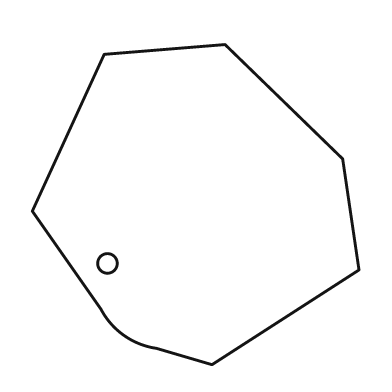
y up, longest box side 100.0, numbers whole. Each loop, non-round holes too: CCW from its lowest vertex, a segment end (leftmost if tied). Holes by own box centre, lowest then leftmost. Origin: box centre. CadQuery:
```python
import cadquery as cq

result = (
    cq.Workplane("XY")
    .moveTo(5.0, -49.0)
    .lineTo(50.0, -20.0)
    .lineTo(45.0, 14.0)
    .lineTo(9.0, 49.0)
    .lineTo(-28.0, 46.0)
    .lineTo(-50.0, -2.0)
    .lineTo(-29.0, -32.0)
    .threePointArc((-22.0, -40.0), (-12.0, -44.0))
    .close()
    .moveTo(-27.0, -18.0)
    .circle(3.0)
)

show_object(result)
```